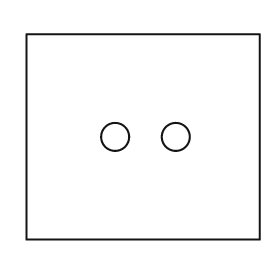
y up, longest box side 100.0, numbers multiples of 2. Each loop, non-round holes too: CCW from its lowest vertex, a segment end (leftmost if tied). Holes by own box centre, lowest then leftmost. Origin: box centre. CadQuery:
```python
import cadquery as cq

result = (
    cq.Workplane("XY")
    .moveTo(-50.0, -44.0)
    .lineTo(50.0, -44.0)
    .lineTo(50.0, 44.0)
    .lineTo(-50.0, 44.0)
    .close()
    .moveTo(-12.0, 0.0)
    .circle(6.0)
    .moveTo(14.0, 0.0)
    .circle(6.0)
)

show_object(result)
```